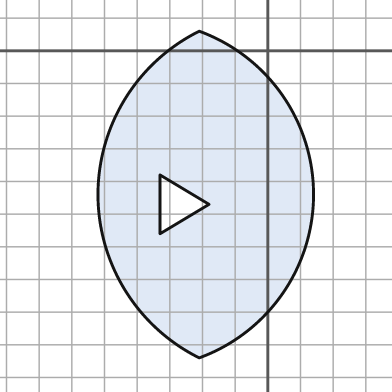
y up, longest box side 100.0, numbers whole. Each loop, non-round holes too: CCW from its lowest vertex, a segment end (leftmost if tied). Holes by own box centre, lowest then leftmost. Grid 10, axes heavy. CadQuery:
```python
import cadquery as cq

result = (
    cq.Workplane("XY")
    .moveTo(-21.0, -94.0)
    .threePointArc((14.0, -44.0), (-21.0, 6.0))
    .threePointArc((-52.0, -44.0), (-21.0, -94.0))
    .close()
    .moveTo(-33.0, -56.0)
    .lineTo(-18.0, -47.0)
    .lineTo(-33.0, -38.0)
    .close()
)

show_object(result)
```